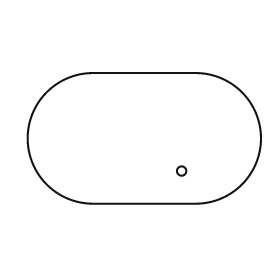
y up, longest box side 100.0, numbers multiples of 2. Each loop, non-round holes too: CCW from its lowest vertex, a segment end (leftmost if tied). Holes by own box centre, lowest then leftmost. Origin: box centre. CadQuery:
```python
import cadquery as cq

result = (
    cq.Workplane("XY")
    .moveTo(-22.0, -28.0)
    .lineTo(22.0, -28.0)
    .threePointArc((50.0, 0.0), (22.0, 28.0))
    .lineTo(-22.0, 28.0)
    .threePointArc((-50.0, 0.0), (-22.0, -28.0))
    .close()
    .moveTo(16.0, -14.0)
    .circle(2.0)
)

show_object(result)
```